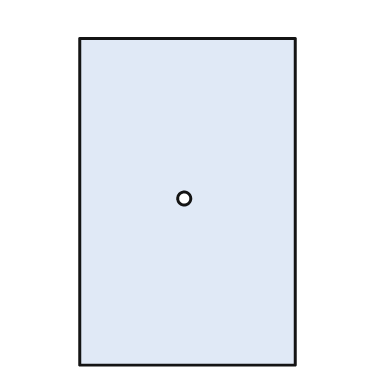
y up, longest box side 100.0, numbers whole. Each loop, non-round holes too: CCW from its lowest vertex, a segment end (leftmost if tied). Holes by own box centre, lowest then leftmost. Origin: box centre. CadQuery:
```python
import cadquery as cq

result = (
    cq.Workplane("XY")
    .moveTo(-33.0, -50.0)
    .lineTo(33.0, -50.0)
    .lineTo(33.0, 50.0)
    .lineTo(-33.0, 50.0)
    .close()
    .moveTo(-1.0, 1.0)
    .circle(2.0)
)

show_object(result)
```